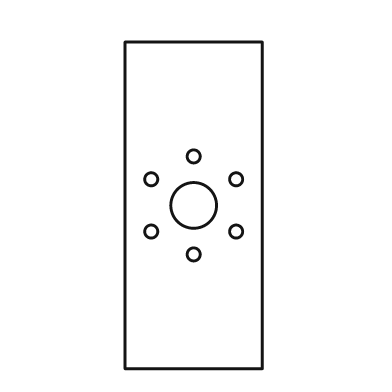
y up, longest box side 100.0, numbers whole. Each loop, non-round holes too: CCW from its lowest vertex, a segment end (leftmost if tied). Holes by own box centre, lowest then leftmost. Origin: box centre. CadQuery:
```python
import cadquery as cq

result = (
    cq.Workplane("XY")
    .moveTo(-21.0, -50.0)
    .lineTo(21.0, -50.0)
    .lineTo(21.0, 50.0)
    .lineTo(-21.0, 50.0)
    .close()
    .moveTo(0.0, -15.0)
    .circle(2.0)
    .moveTo(-13.0, -8.0)
    .circle(2.0)
    .moveTo(13.0, -8.0)
    .circle(2.0)
    .moveTo(0.0, 0.0)
    .circle(7.0)
    .moveTo(-13.0, 8.0)
    .circle(2.0)
    .moveTo(13.0, 8.0)
    .circle(2.0)
    .moveTo(0.0, 15.0)
    .circle(2.0)
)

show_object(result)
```